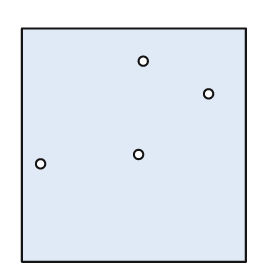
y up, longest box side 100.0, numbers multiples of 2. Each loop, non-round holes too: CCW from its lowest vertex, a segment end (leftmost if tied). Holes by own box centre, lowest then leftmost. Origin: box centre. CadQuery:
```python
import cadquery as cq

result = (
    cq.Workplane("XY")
    .moveTo(-48.0, -50.0)
    .lineTo(48.0, -50.0)
    .lineTo(48.0, 50.0)
    .lineTo(-48.0, 50.0)
    .close()
    .moveTo(-40.0, -8.0)
    .circle(2.0)
    .moveTo(2.0, -4.0)
    .circle(2.0)
    .moveTo(32.0, 22.0)
    .circle(2.0)
    .moveTo(4.0, 36.0)
    .circle(2.0)
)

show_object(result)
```